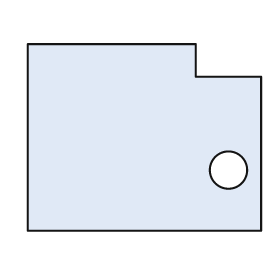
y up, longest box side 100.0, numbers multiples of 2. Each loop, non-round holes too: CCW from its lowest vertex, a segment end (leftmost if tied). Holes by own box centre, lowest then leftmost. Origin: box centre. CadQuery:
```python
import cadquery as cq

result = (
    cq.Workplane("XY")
    .moveTo(-50.0, -40.0)
    .lineTo(50.0, -40.0)
    .lineTo(50.0, 26.0)
    .lineTo(22.0, 26.0)
    .lineTo(22.0, 40.0)
    .lineTo(-50.0, 40.0)
    .close()
    .moveTo(36.0, -14.0)
    .circle(8.0)
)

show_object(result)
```